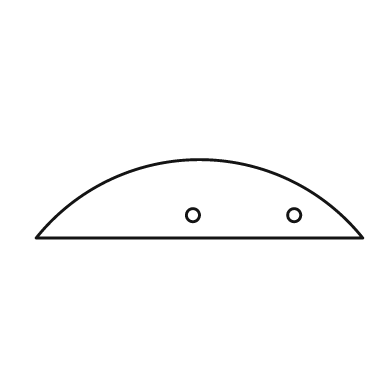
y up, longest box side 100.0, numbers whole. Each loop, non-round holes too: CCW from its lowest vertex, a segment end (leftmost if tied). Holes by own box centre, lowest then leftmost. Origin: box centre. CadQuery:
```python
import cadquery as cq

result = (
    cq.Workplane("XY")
    .moveTo(-50.0, -12.0)
    .lineTo(50.0, -12.0)
    .threePointArc((0.0, 12.0), (-50.0, -12.0))
    .close()
    .moveTo(-2.0, -5.0)
    .circle(2.0)
    .moveTo(29.0, -5.0)
    .circle(2.0)
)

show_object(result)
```